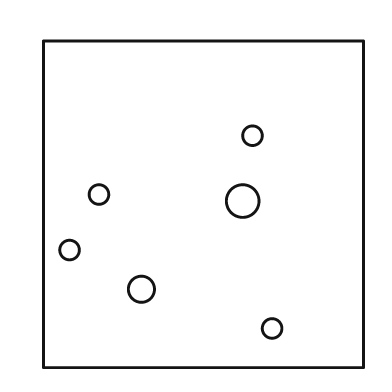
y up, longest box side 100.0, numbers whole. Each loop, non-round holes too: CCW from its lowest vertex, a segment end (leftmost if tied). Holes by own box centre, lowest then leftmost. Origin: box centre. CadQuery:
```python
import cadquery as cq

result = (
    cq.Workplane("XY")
    .moveTo(-49.0, -50.0)
    .lineTo(49.0, -50.0)
    .lineTo(49.0, 50.0)
    .lineTo(-49.0, 50.0)
    .close()
    .moveTo(21.0, -38.0)
    .circle(3.0)
    .moveTo(-19.0, -26.0)
    .circle(4.0)
    .moveTo(-41.0, -14.0)
    .circle(3.0)
    .moveTo(12.0, 1.0)
    .circle(5.0)
    .moveTo(-32.0, 3.0)
    .circle(3.0)
    .moveTo(15.0, 21.0)
    .circle(3.0)
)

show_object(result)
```